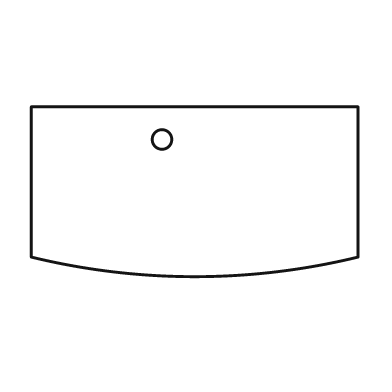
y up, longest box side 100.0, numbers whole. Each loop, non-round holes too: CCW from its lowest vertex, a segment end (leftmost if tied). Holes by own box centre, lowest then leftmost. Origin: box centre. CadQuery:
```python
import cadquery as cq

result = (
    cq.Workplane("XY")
    .moveTo(-50.0, -20.0)
    .threePointArc((0.0, -26.0), (50.0, -20.0))
    .lineTo(50.0, 26.0)
    .lineTo(-50.0, 26.0)
    .close()
    .moveTo(-10.0, 16.0)
    .circle(3.0)
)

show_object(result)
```